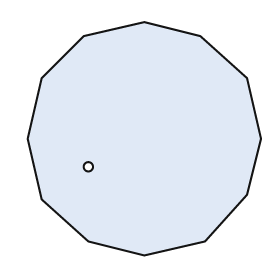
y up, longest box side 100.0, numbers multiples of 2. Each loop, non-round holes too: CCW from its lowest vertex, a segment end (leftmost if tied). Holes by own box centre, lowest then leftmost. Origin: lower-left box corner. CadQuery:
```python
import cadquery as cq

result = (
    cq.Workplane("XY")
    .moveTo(50.0, 0.0)
    .lineTo(76.0, 6.0)
    .lineTo(94.0, 26.0)
    .lineTo(100.0, 50.0)
    .lineTo(94.0, 76.0)
    .lineTo(74.0, 94.0)
    .lineTo(50.0, 100.0)
    .lineTo(24.0, 94.0)
    .lineTo(6.0, 76.0)
    .lineTo(0.0, 50.0)
    .lineTo(6.0, 24.0)
    .lineTo(26.0, 6.0)
    .close()
    .moveTo(26.0, 38.0)
    .circle(2.0)
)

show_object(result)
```